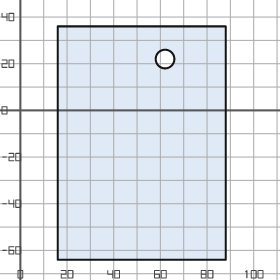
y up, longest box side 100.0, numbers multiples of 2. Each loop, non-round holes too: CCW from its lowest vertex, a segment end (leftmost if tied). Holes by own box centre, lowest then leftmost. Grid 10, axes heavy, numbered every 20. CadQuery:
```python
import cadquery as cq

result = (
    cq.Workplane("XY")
    .moveTo(16.0, -64.0)
    .lineTo(88.0, -64.0)
    .lineTo(88.0, 36.0)
    .lineTo(16.0, 36.0)
    .close()
    .moveTo(62.0, 22.0)
    .circle(4.0)
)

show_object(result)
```